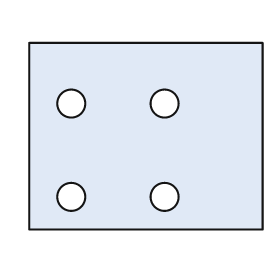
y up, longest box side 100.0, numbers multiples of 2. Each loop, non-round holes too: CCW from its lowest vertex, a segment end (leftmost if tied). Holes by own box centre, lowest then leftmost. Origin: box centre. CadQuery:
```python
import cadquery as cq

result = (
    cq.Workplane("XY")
    .moveTo(-50.0, -40.0)
    .lineTo(50.0, -40.0)
    .lineTo(50.0, 40.0)
    .lineTo(-50.0, 40.0)
    .close()
    .moveTo(-32.0, -26.0)
    .circle(6.0)
    .moveTo(8.0, -26.0)
    .circle(6.0)
    .moveTo(-32.0, 14.0)
    .circle(6.0)
    .moveTo(8.0, 14.0)
    .circle(6.0)
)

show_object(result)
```